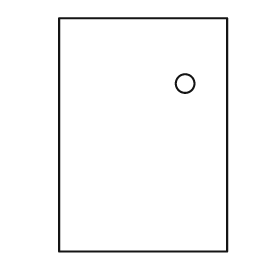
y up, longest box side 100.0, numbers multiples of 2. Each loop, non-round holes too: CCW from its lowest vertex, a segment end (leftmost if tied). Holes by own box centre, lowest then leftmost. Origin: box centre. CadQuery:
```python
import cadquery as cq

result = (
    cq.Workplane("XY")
    .moveTo(-36.0, -50.0)
    .lineTo(36.0, -50.0)
    .lineTo(36.0, 50.0)
    .lineTo(-36.0, 50.0)
    .close()
    .moveTo(18.0, 22.0)
    .circle(4.0)
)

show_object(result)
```